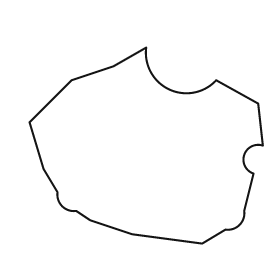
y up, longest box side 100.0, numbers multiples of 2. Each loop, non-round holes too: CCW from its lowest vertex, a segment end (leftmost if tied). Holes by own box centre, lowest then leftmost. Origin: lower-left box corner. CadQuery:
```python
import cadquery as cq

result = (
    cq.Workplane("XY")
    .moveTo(74.0, 0.0)
    .lineTo(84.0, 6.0)
    .threePointArc((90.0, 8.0), (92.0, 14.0))
    .lineTo(96.0, 30.0)
    .threePointArc((92.0, 38.0), (100.0, 42.0))
    .lineTo(98.0, 60.0)
    .lineTo(80.0, 70.0)
    .threePointArc((60.0, 66.0), (50.0, 84.0))
    .lineTo(36.0, 76.0)
    .lineTo(18.0, 70.0)
    .lineTo(0.0, 52.0)
    .lineTo(6.0, 32.0)
    .lineTo(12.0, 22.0)
    .threePointArc((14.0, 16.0), (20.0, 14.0))
    .lineTo(26.0, 10.0)
    .lineTo(44.0, 4.0)
    .close()
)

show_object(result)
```